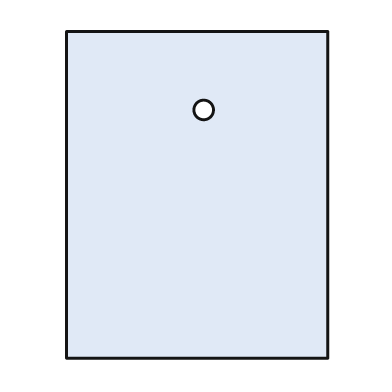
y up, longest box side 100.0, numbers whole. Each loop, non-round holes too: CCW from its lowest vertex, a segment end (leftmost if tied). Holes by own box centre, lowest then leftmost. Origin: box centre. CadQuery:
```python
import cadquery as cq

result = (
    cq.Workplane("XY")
    .moveTo(-40.0, -50.0)
    .lineTo(40.0, -50.0)
    .lineTo(40.0, 50.0)
    .lineTo(-40.0, 50.0)
    .close()
    .moveTo(2.0, 26.0)
    .circle(3.0)
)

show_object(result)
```